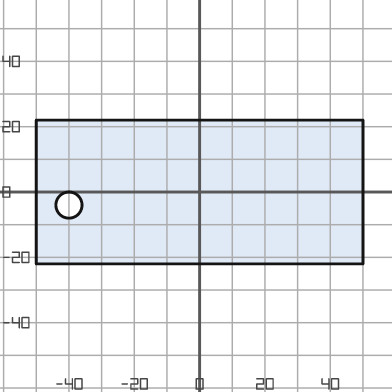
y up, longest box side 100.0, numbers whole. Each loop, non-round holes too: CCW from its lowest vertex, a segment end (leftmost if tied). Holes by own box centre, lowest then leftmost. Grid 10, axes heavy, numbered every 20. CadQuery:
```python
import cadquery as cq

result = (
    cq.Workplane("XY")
    .moveTo(-50.0, -22.0)
    .lineTo(50.0, -22.0)
    .lineTo(50.0, 22.0)
    .lineTo(-50.0, 22.0)
    .close()
    .moveTo(-40.0, -4.0)
    .circle(4.0)
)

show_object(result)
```